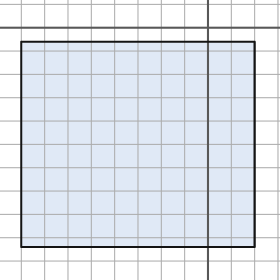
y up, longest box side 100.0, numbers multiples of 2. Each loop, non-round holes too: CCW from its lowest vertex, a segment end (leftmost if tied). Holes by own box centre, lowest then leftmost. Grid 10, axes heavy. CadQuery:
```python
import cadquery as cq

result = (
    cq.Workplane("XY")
    .moveTo(-80.0, -94.0)
    .lineTo(20.0, -94.0)
    .lineTo(20.0, -6.0)
    .lineTo(-80.0, -6.0)
    .close()
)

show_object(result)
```